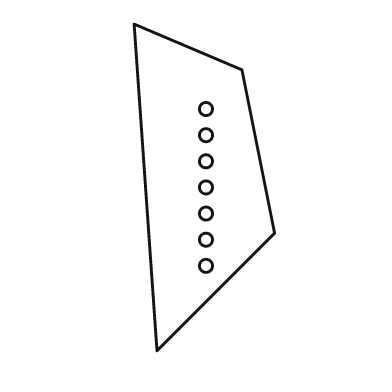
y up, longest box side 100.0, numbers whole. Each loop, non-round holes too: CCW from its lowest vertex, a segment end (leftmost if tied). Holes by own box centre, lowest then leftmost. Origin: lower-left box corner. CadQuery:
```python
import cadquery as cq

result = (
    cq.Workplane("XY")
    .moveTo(7.0, 0.0)
    .lineTo(43.0, 36.0)
    .lineTo(33.0, 86.0)
    .lineTo(0.0, 100.0)
    .close()
    .moveTo(22.0, 26.0)
    .circle(2.0)
    .moveTo(22.0, 34.0)
    .circle(2.0)
    .moveTo(22.0, 42.0)
    .circle(2.0)
    .moveTo(22.0, 50.0)
    .circle(2.0)
    .moveTo(22.0, 58.0)
    .circle(2.0)
    .moveTo(22.0, 66.0)
    .circle(2.0)
    .moveTo(22.0, 74.0)
    .circle(2.0)
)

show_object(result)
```